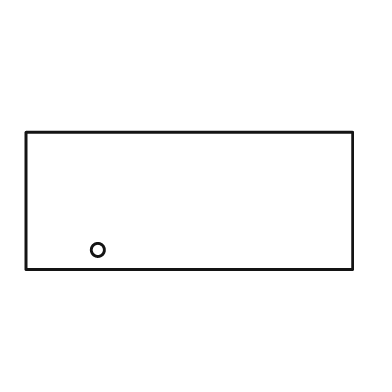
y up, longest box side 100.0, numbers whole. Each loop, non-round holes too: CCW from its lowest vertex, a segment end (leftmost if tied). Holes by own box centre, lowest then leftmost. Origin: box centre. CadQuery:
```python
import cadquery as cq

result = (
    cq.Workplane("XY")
    .moveTo(-50.0, -21.0)
    .lineTo(50.0, -21.0)
    .lineTo(50.0, 21.0)
    .lineTo(-50.0, 21.0)
    .close()
    .moveTo(-28.0, -15.0)
    .circle(2.0)
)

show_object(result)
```